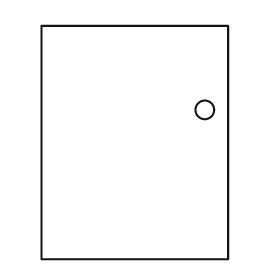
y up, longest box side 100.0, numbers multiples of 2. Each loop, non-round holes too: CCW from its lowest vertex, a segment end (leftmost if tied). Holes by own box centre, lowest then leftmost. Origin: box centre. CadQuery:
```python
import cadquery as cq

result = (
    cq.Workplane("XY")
    .moveTo(-40.0, -50.0)
    .lineTo(40.0, -50.0)
    .lineTo(40.0, 50.0)
    .lineTo(-40.0, 50.0)
    .close()
    .moveTo(30.0, 14.0)
    .circle(4.0)
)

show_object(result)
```